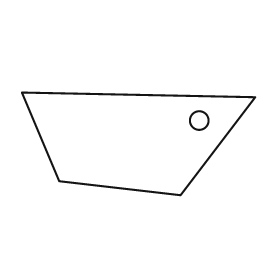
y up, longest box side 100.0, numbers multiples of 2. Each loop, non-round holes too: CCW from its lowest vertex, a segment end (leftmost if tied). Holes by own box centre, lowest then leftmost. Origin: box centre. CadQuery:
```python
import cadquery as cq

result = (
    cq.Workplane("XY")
    .moveTo(18.0, -22.0)
    .lineTo(50.0, 20.0)
    .lineTo(-50.0, 22.0)
    .lineTo(-34.0, -16.0)
    .close()
    .moveTo(26.0, 10.0)
    .circle(4.0)
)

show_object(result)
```